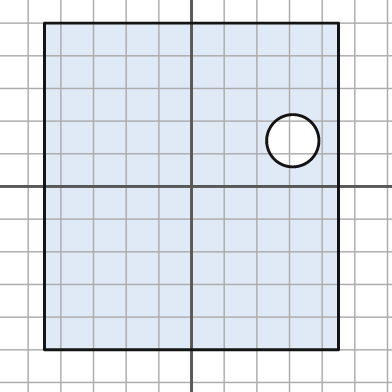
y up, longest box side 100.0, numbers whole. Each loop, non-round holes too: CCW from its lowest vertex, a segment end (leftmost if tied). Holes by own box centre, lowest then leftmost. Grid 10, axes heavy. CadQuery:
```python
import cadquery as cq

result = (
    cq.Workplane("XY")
    .moveTo(-45.0, -50.0)
    .lineTo(45.0, -50.0)
    .lineTo(45.0, 50.0)
    .lineTo(-45.0, 50.0)
    .close()
    .moveTo(31.0, 14.0)
    .circle(8.0)
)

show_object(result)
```